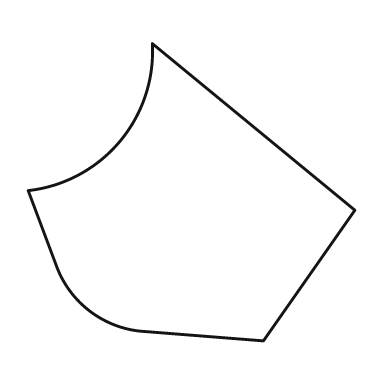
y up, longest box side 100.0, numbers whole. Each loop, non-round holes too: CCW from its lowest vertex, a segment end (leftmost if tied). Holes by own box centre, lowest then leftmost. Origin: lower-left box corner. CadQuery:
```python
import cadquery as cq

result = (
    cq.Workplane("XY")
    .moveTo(72.0, 0.0)
    .lineTo(100.0, 40.0)
    .lineTo(38.0, 91.0)
    .threePointArc((28.0, 61.0), (0.0, 46.0))
    .lineTo(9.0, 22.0)
    .threePointArc((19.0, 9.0), (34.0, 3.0))
    .close()
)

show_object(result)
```